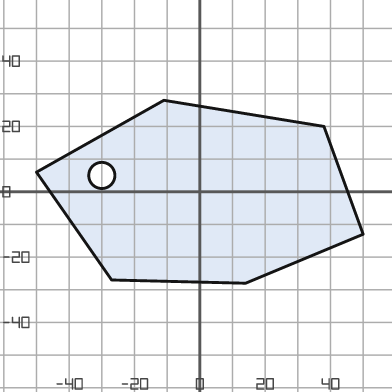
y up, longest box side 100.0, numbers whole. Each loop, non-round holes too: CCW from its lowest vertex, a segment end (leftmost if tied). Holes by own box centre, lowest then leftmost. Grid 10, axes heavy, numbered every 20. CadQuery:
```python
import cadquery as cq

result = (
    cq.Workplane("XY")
    .moveTo(14.0, -28.0)
    .lineTo(50.0, -13.0)
    .lineTo(38.0, 20.0)
    .lineTo(-11.0, 28.0)
    .lineTo(-50.0, 6.0)
    .lineTo(-27.0, -27.0)
    .close()
    .moveTo(-30.0, 5.0)
    .circle(4.0)
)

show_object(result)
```